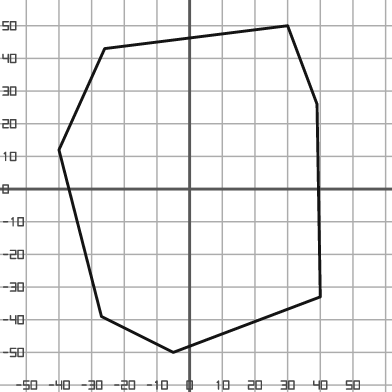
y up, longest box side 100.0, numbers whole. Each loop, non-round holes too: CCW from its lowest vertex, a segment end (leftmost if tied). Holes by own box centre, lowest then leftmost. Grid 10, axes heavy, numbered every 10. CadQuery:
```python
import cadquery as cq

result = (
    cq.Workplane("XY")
    .moveTo(-5.0, -50.0)
    .lineTo(40.0, -33.0)
    .lineTo(39.0, 26.0)
    .lineTo(30.0, 50.0)
    .lineTo(-26.0, 43.0)
    .lineTo(-40.0, 12.0)
    .lineTo(-27.0, -39.0)
    .close()
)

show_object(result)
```